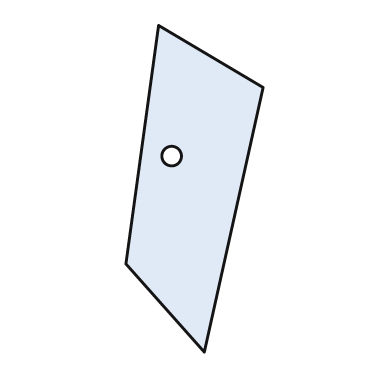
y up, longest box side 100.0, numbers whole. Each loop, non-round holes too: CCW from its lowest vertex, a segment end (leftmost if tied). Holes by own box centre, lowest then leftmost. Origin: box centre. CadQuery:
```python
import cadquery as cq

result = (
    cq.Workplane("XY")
    .moveTo(3.0, -50.0)
    .lineTo(21.0, 31.0)
    .lineTo(-11.0, 50.0)
    .lineTo(-21.0, -23.0)
    .close()
    .moveTo(-7.0, 10.0)
    .circle(3.0)
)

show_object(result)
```